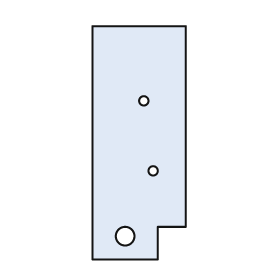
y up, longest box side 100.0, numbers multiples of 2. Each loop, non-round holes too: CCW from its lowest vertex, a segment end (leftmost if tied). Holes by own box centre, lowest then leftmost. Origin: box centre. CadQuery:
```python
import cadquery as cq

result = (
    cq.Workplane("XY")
    .moveTo(-20.0, -50.0)
    .lineTo(8.0, -50.0)
    .lineTo(8.0, -36.0)
    .lineTo(20.0, -36.0)
    .lineTo(20.0, 50.0)
    .lineTo(-20.0, 50.0)
    .close()
    .moveTo(-6.0, -40.0)
    .circle(4.0)
    .moveTo(6.0, -12.0)
    .circle(2.0)
    .moveTo(2.0, 18.0)
    .circle(2.0)
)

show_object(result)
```